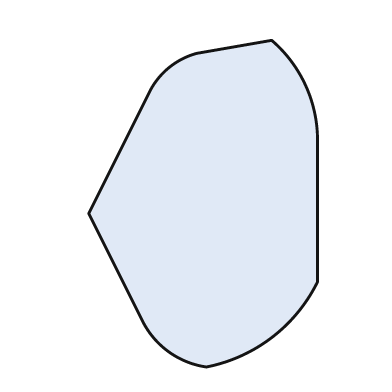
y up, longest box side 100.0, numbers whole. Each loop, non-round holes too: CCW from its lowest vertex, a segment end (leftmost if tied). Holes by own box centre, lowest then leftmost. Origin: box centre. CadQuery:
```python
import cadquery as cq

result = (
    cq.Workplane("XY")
    .moveTo(1.0, -50.0)
    .threePointArc((21.0, -41.0), (35.0, -24.0))
    .lineTo(35.0, 21.0)
    .threePointArc((31.0, 37.0), (21.0, 50.0))
    .lineTo(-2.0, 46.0)
    .threePointArc((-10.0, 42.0), (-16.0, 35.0))
    .lineTo(-35.0, -3.0)
    .lineTo(-19.0, -35.0)
    .threePointArc((-11.0, -45.0), (1.0, -50.0))
    .close()
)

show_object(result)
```